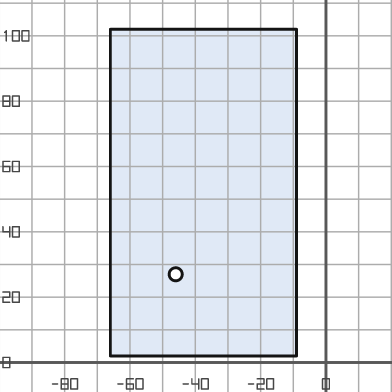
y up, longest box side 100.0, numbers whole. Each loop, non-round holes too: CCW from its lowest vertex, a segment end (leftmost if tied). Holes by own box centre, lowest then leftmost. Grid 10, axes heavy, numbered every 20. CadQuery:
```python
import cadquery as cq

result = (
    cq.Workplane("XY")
    .moveTo(-66.0, 2.0)
    .lineTo(-9.0, 2.0)
    .lineTo(-9.0, 102.0)
    .lineTo(-66.0, 102.0)
    .close()
    .moveTo(-46.0, 27.0)
    .circle(2.0)
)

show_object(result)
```